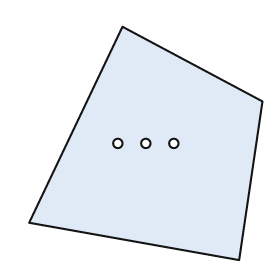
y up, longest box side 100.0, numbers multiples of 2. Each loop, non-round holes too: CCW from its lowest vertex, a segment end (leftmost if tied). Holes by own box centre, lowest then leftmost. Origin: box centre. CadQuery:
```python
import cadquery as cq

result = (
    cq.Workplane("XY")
    .moveTo(40.0, -50.0)
    .lineTo(50.0, 18.0)
    .lineTo(-10.0, 50.0)
    .lineTo(-50.0, -34.0)
    .close()
    .moveTo(-12.0, 0.0)
    .circle(2.0)
    .moveTo(0.0, 0.0)
    .circle(2.0)
    .moveTo(12.0, 0.0)
    .circle(2.0)
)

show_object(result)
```